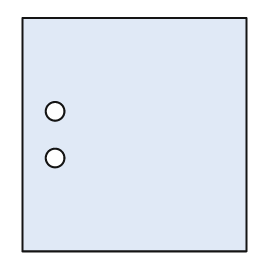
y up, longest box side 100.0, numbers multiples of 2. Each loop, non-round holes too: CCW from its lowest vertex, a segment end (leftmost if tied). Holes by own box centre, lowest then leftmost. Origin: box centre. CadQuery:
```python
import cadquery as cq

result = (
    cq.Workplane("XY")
    .moveTo(-48.0, -50.0)
    .lineTo(48.0, -50.0)
    .lineTo(48.0, 50.0)
    .lineTo(-48.0, 50.0)
    .close()
    .moveTo(-34.0, -10.0)
    .circle(4.0)
    .moveTo(-34.0, 10.0)
    .circle(4.0)
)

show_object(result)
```